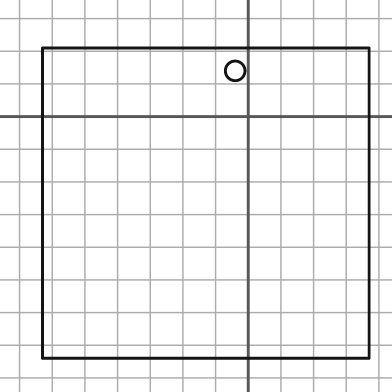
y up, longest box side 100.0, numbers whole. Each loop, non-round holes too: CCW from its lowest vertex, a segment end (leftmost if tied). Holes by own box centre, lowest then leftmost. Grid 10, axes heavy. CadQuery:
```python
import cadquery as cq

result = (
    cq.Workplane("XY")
    .moveTo(-63.0, -74.0)
    .lineTo(37.0, -74.0)
    .lineTo(37.0, 21.0)
    .lineTo(-63.0, 21.0)
    .close()
    .moveTo(-4.0, 14.0)
    .circle(3.0)
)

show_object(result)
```